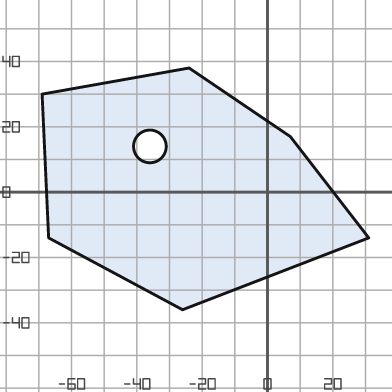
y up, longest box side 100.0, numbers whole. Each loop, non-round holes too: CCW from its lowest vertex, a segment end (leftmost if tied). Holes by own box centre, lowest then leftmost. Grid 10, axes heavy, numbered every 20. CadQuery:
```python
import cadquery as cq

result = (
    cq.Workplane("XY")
    .moveTo(-26.0, -36.0)
    .lineTo(31.0, -14.0)
    .lineTo(7.0, 17.0)
    .lineTo(-24.0, 38.0)
    .lineTo(-69.0, 30.0)
    .lineTo(-67.0, -14.0)
    .close()
    .moveTo(-36.0, 14.0)
    .circle(5.0)
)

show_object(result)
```